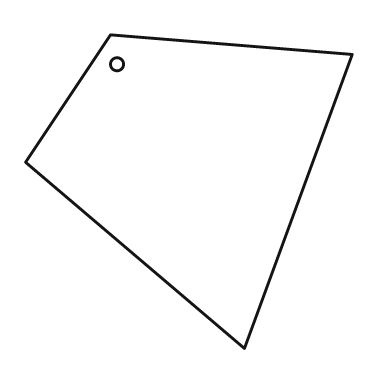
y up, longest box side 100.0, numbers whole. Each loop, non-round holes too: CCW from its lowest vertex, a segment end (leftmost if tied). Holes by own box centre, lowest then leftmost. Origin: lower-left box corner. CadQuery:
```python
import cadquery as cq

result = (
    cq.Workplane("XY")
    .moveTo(67.0, 0.0)
    .lineTo(100.0, 90.0)
    .lineTo(26.0, 96.0)
    .lineTo(0.0, 57.0)
    .close()
    .moveTo(28.0, 87.0)
    .circle(2.0)
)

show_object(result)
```